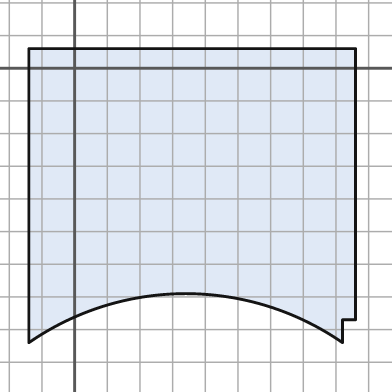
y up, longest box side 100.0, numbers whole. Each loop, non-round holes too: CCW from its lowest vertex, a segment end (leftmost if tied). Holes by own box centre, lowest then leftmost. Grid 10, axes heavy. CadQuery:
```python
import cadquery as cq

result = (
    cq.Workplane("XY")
    .moveTo(-14.0, -84.0)
    .threePointArc((34.0, -69.0), (82.0, -84.0))
    .lineTo(82.0, -77.0)
    .lineTo(86.0, -77.0)
    .lineTo(86.0, 6.0)
    .lineTo(-14.0, 6.0)
    .close()
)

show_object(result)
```